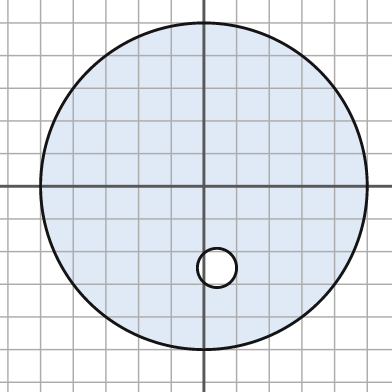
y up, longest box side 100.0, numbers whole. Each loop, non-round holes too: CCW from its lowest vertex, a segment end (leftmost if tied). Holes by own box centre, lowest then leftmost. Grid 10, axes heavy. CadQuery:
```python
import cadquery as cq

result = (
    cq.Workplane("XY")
    .moveTo(0.0, 0.0)
    .circle(50.0)
    .moveTo(4.0, -25.0)
    .circle(6.0)
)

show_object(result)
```